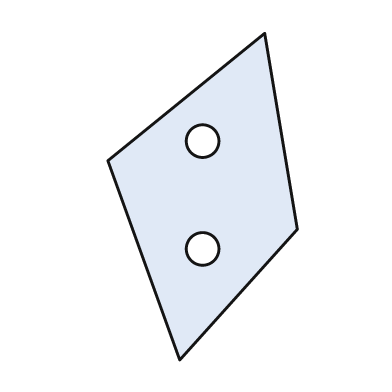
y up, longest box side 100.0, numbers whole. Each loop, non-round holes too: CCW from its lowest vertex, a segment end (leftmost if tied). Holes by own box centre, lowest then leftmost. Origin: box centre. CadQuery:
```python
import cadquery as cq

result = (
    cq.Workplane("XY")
    .moveTo(-7.0, -50.0)
    .lineTo(29.0, -10.0)
    .lineTo(19.0, 50.0)
    .lineTo(-29.0, 11.0)
    .close()
    .moveTo(0.0, -16.0)
    .circle(5.0)
    .moveTo(0.0, 17.0)
    .circle(5.0)
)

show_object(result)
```